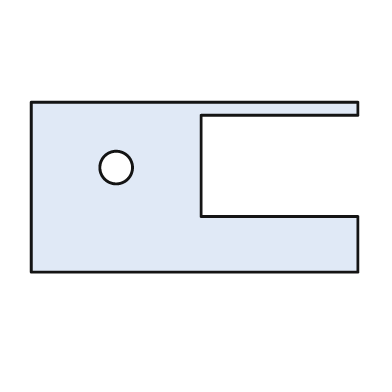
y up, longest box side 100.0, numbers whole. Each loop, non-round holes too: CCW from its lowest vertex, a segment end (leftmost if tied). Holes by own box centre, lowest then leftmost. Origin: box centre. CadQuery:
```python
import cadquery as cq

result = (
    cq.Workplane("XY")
    .moveTo(-50.0, -26.0)
    .lineTo(50.0, -26.0)
    .lineTo(50.0, -9.0)
    .lineTo(2.0, -9.0)
    .lineTo(2.0, 22.0)
    .lineTo(50.0, 22.0)
    .lineTo(50.0, 26.0)
    .lineTo(-50.0, 26.0)
    .close()
    .moveTo(-24.0, 6.0)
    .circle(5.0)
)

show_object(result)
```